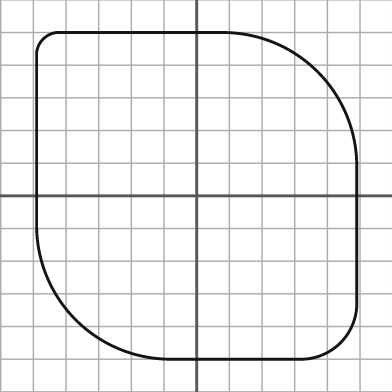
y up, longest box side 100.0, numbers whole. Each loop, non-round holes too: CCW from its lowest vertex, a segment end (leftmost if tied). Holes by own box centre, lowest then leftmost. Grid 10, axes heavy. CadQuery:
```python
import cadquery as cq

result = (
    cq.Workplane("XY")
    .moveTo(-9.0, -50.0)
    .lineTo(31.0, -50.0)
    .threePointArc((44.0, -45.0), (49.0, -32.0))
    .lineTo(49.0, 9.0)
    .threePointArc((37.0, 38.0), (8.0, 50.0))
    .lineTo(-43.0, 50.0)
    .threePointArc((-47.0, 48.0), (-49.0, 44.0))
    .lineTo(-49.0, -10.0)
    .threePointArc((-37.0, -38.0), (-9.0, -50.0))
    .close()
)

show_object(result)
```